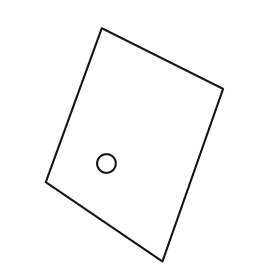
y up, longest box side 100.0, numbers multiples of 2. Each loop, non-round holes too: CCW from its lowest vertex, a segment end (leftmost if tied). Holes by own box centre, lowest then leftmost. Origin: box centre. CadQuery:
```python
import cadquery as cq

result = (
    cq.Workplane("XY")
    .moveTo(12.0, -50.0)
    .lineTo(38.0, 24.0)
    .lineTo(-14.0, 50.0)
    .lineTo(-38.0, -16.0)
    .close()
    .moveTo(-12.0, -8.0)
    .circle(4.0)
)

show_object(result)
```